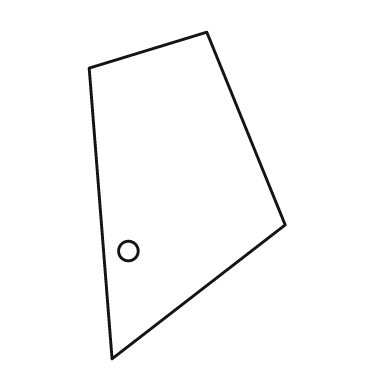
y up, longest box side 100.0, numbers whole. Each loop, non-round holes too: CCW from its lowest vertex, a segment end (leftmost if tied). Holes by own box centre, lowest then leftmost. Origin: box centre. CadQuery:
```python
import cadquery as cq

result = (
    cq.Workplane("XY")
    .moveTo(-23.0, -50.0)
    .lineTo(30.0, -9.0)
    .lineTo(6.0, 50.0)
    .lineTo(-30.0, 39.0)
    .close()
    .moveTo(-18.0, -17.0)
    .circle(3.0)
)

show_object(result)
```